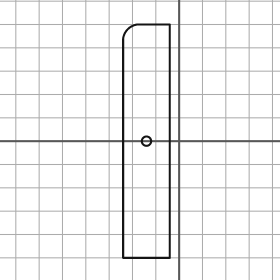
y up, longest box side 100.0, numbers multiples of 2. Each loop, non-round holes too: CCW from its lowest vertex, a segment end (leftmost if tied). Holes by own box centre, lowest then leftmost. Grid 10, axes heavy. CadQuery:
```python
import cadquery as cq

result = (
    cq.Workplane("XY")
    .moveTo(-24.0, -50.0)
    .lineTo(-4.0, -50.0)
    .lineTo(-4.0, 50.0)
    .lineTo(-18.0, 50.0)
    .threePointArc((-22.0, 48.0), (-24.0, 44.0))
    .close()
    .moveTo(-14.0, 0.0)
    .circle(2.0)
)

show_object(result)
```